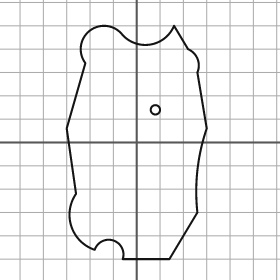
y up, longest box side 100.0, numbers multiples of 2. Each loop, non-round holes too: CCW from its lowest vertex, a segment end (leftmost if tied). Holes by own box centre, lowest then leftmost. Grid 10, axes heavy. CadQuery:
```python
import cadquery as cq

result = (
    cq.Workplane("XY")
    .moveTo(-6.0, -50.0)
    .lineTo(14.0, -50.0)
    .lineTo(26.0, -30.0)
    .threePointArc((26.0, -12.0), (30.0, 6.0))
    .lineTo(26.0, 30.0)
    .threePointArc((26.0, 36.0), (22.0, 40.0))
    .lineTo(16.0, 50.0)
    .threePointArc((6.0, 42.0), (-6.0, 46.0))
    .threePointArc((-20.0, 48.0), (-22.0, 34.0))
    .lineTo(-30.0, 6.0)
    .lineTo(-26.0, -22.0)
    .threePointArc((-28.0, -36.0), (-18.0, -46.0))
    .threePointArc((-10.0, -42.0), (-6.0, -50.0))
    .close()
    .moveTo(8.0, 14.0)
    .circle(2.0)
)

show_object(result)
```